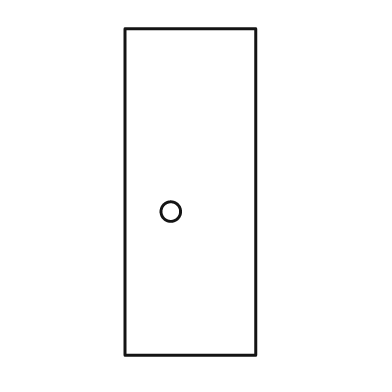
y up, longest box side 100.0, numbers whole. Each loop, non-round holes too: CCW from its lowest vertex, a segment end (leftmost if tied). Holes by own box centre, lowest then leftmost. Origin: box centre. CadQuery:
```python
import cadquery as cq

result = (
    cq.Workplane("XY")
    .moveTo(-20.0, -50.0)
    .lineTo(20.0, -50.0)
    .lineTo(20.0, 50.0)
    .lineTo(-20.0, 50.0)
    .close()
    .moveTo(-6.0, -6.0)
    .circle(3.0)
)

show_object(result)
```